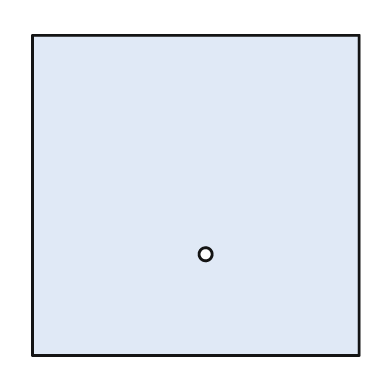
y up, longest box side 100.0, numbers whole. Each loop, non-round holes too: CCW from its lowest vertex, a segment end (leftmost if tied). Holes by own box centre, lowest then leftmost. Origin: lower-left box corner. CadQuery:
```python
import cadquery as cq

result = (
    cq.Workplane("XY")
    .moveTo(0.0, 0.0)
    .lineTo(100.0, 0.0)
    .lineTo(100.0, 98.0)
    .lineTo(0.0, 98.0)
    .close()
    .moveTo(53.0, 31.0)
    .circle(2.0)
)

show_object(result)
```